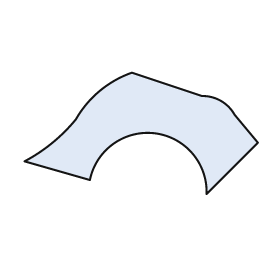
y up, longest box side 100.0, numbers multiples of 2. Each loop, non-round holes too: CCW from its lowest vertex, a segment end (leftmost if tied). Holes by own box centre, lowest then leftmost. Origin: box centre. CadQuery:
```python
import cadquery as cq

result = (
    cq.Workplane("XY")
    .moveTo(28.0, -26.0)
    .lineTo(50.0, -4.0)
    .lineTo(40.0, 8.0)
    .threePointArc((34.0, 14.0), (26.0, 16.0))
    .lineTo(-4.0, 26.0)
    .threePointArc((-18.0, 18.0), (-28.0, 6.0))
    .threePointArc((-38.0, -4.0), (-50.0, -12.0))
    .lineTo(-22.0, -20.0)
    .threePointArc((6.0, 0.0), (28.0, -26.0))
    .close()
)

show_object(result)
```